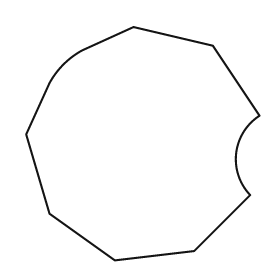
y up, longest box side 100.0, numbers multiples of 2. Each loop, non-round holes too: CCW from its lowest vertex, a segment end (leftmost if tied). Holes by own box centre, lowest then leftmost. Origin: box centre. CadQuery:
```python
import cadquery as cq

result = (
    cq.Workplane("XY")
    .moveTo(-12.0, -50.0)
    .lineTo(22.0, -46.0)
    .lineTo(46.0, -22.0)
    .threePointArc((40.0, -4.0), (50.0, 12.0))
    .lineTo(30.0, 42.0)
    .lineTo(-4.0, 50.0)
    .lineTo(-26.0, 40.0)
    .threePointArc((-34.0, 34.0), (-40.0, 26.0))
    .lineTo(-50.0, 4.0)
    .lineTo(-40.0, -30.0)
    .close()
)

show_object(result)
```